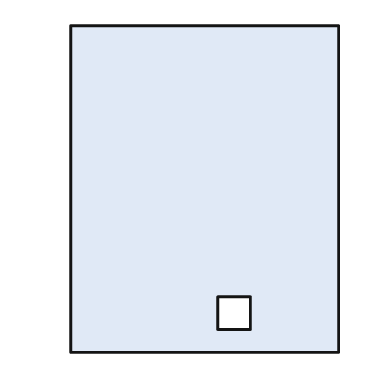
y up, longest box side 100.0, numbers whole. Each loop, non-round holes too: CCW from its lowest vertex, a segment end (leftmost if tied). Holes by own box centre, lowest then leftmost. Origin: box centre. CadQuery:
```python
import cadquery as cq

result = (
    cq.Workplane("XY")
    .moveTo(-41.0, -50.0)
    .lineTo(41.0, -50.0)
    .lineTo(41.0, 50.0)
    .lineTo(-41.0, 50.0)
    .close()
    .moveTo(4.0, -43.0)
    .lineTo(14.0, -43.0)
    .lineTo(14.0, -33.0)
    .lineTo(4.0, -33.0)
    .close()
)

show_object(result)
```